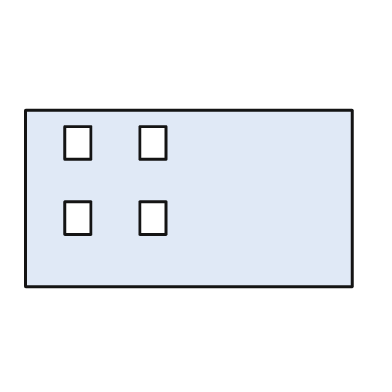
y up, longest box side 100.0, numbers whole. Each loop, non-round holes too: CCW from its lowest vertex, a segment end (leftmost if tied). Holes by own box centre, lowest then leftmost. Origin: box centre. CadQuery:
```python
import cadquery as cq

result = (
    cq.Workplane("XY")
    .moveTo(-50.0, -27.0)
    .lineTo(50.0, -27.0)
    .lineTo(50.0, 27.0)
    .lineTo(-50.0, 27.0)
    .close()
    .moveTo(-38.0, -11.0)
    .lineTo(-30.0, -11.0)
    .lineTo(-30.0, -1.0)
    .lineTo(-38.0, -1.0)
    .close()
    .moveTo(-15.0, -11.0)
    .lineTo(-7.0, -11.0)
    .lineTo(-7.0, -1.0)
    .lineTo(-15.0, -1.0)
    .close()
    .moveTo(-38.0, 12.0)
    .lineTo(-30.0, 12.0)
    .lineTo(-30.0, 22.0)
    .lineTo(-38.0, 22.0)
    .close()
    .moveTo(-15.0, 12.0)
    .lineTo(-7.0, 12.0)
    .lineTo(-7.0, 22.0)
    .lineTo(-15.0, 22.0)
    .close()
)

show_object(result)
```